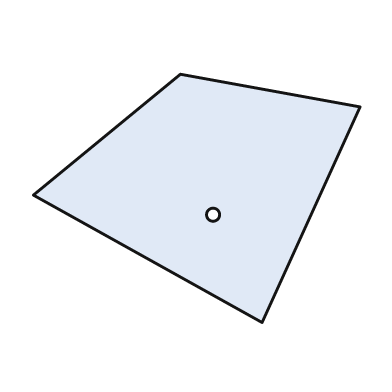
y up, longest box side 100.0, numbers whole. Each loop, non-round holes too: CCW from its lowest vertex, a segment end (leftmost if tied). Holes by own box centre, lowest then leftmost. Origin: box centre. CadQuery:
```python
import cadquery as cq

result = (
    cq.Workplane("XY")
    .moveTo(20.0, -38.0)
    .lineTo(50.0, 28.0)
    .lineTo(-5.0, 38.0)
    .lineTo(-50.0, 1.0)
    .close()
    .moveTo(5.0, -5.0)
    .circle(2.0)
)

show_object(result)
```